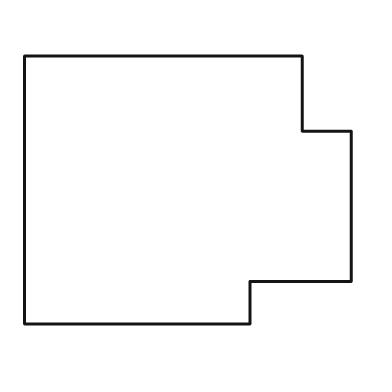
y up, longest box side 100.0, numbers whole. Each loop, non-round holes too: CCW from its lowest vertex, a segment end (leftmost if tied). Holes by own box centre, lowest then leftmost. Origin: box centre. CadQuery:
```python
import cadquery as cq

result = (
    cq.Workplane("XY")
    .moveTo(-50.0, -41.0)
    .lineTo(19.0, -41.0)
    .lineTo(19.0, -28.0)
    .lineTo(50.0, -28.0)
    .lineTo(50.0, 18.0)
    .lineTo(35.0, 18.0)
    .lineTo(35.0, 41.0)
    .lineTo(-50.0, 41.0)
    .close()
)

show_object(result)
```